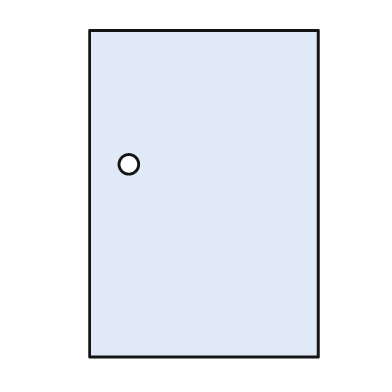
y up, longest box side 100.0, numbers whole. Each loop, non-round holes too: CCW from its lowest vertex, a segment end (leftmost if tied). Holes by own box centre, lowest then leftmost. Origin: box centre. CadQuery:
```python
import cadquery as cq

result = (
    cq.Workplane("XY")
    .moveTo(-35.0, -50.0)
    .lineTo(35.0, -50.0)
    .lineTo(35.0, 50.0)
    .lineTo(-35.0, 50.0)
    .close()
    .moveTo(-23.0, 9.0)
    .circle(3.0)
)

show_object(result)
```